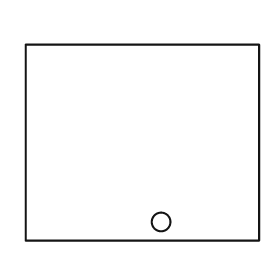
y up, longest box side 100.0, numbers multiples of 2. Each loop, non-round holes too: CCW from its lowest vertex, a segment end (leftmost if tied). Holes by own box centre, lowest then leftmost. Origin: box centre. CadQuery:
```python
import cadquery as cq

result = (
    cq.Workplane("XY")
    .moveTo(-50.0, -42.0)
    .lineTo(50.0, -42.0)
    .lineTo(50.0, 42.0)
    .lineTo(-50.0, 42.0)
    .close()
    .moveTo(8.0, -34.0)
    .circle(4.0)
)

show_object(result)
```